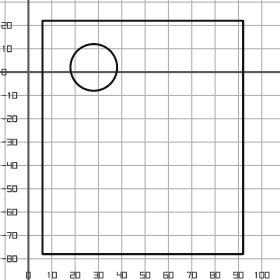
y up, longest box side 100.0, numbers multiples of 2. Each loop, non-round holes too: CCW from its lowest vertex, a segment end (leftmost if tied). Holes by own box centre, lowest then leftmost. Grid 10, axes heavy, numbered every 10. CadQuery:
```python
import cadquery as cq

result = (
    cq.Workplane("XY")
    .moveTo(6.0, -78.0)
    .lineTo(92.0, -78.0)
    .lineTo(92.0, 22.0)
    .lineTo(6.0, 22.0)
    .close()
    .moveTo(28.0, 2.0)
    .circle(10.0)
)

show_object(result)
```